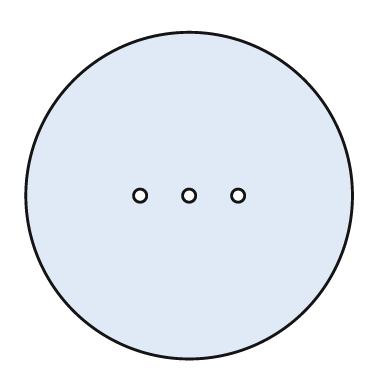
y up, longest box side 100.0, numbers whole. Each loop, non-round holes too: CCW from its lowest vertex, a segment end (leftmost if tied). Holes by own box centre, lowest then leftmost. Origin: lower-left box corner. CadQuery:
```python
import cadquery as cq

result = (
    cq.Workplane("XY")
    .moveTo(50.0, 50.0)
    .circle(50.0)
    .moveTo(35.0, 50.0)
    .circle(2.0)
    .moveTo(50.0, 50.0)
    .circle(2.0)
    .moveTo(65.0, 50.0)
    .circle(2.0)
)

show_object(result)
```